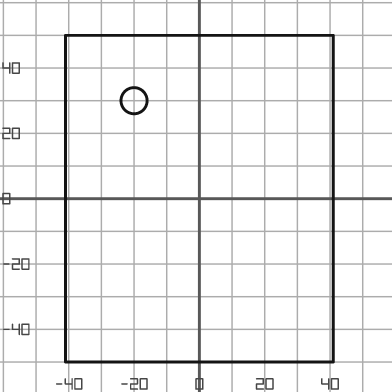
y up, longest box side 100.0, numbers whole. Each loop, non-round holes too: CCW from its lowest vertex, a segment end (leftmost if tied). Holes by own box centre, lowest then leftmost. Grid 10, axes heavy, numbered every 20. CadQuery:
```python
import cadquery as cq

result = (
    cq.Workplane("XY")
    .moveTo(-41.0, -50.0)
    .lineTo(41.0, -50.0)
    .lineTo(41.0, 50.0)
    .lineTo(-41.0, 50.0)
    .close()
    .moveTo(-20.0, 30.0)
    .circle(4.0)
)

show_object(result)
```